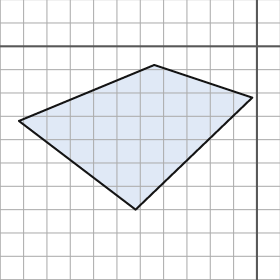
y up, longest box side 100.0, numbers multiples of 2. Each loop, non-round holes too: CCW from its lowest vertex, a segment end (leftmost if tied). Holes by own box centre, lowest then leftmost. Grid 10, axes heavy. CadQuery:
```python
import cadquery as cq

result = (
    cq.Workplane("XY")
    .moveTo(-52.0, -70.0)
    .lineTo(-2.0, -22.0)
    .lineTo(-44.0, -8.0)
    .lineTo(-102.0, -32.0)
    .close()
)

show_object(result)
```